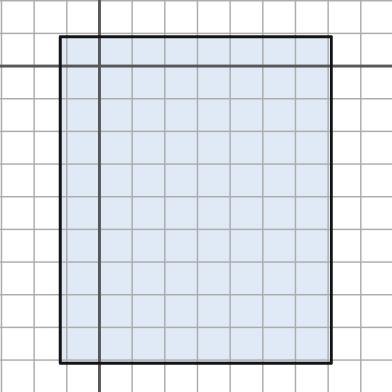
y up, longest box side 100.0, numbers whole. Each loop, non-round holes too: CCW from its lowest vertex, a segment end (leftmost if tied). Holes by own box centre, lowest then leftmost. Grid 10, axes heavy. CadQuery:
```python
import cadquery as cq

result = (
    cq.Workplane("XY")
    .moveTo(-12.0, -91.0)
    .lineTo(71.0, -91.0)
    .lineTo(71.0, 9.0)
    .lineTo(-12.0, 9.0)
    .close()
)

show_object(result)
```